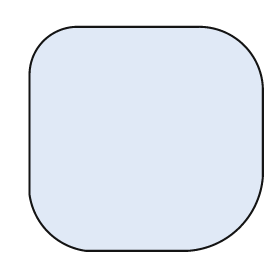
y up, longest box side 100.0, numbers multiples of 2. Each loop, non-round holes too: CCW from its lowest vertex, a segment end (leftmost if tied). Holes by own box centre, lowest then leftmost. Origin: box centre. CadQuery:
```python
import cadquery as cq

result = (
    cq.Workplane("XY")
    .moveTo(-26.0, -48.0)
    .lineTo(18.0, -48.0)
    .threePointArc((40.0, -38.0), (50.0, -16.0))
    .lineTo(50.0, 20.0)
    .threePointArc((42.0, 40.0), (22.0, 48.0))
    .lineTo(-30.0, 48.0)
    .threePointArc((-44.0, 42.0), (-50.0, 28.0))
    .lineTo(-50.0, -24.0)
    .threePointArc((-42.0, -40.0), (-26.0, -48.0))
    .close()
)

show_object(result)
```